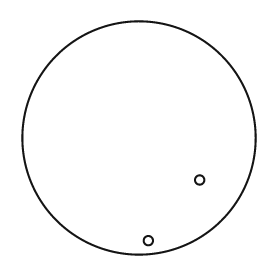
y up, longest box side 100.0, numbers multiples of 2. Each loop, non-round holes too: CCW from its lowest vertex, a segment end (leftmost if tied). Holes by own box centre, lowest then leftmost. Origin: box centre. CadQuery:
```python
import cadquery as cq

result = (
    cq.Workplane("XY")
    .moveTo(0.0, 0.0)
    .circle(50.0)
    .moveTo(4.0, -44.0)
    .circle(2.0)
    .moveTo(26.0, -18.0)
    .circle(2.0)
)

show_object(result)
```